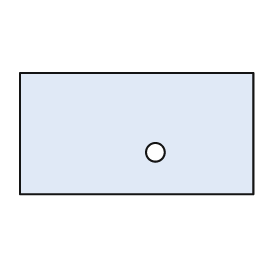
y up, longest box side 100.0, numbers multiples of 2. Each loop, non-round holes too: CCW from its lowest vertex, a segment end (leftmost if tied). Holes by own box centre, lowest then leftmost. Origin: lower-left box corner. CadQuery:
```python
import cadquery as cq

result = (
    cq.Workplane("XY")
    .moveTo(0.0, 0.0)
    .lineTo(100.0, 0.0)
    .lineTo(100.0, 52.0)
    .lineTo(0.0, 52.0)
    .close()
    .moveTo(58.0, 18.0)
    .circle(4.0)
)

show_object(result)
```